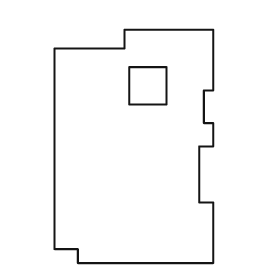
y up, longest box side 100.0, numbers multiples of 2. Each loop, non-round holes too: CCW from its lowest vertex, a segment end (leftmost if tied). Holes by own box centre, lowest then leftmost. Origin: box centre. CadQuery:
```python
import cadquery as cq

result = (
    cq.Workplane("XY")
    .moveTo(-24.0, -50.0)
    .lineTo(34.0, -50.0)
    .lineTo(34.0, -24.0)
    .lineTo(28.0, -24.0)
    .lineTo(28.0, 0.0)
    .lineTo(34.0, 0.0)
    .lineTo(34.0, 10.0)
    .lineTo(30.0, 10.0)
    .lineTo(30.0, 24.0)
    .lineTo(34.0, 24.0)
    .lineTo(34.0, 50.0)
    .lineTo(-4.0, 50.0)
    .lineTo(-4.0, 42.0)
    .lineTo(-34.0, 42.0)
    .lineTo(-34.0, -44.0)
    .lineTo(-24.0, -44.0)
    .close()
    .moveTo(-2.0, 18.0)
    .lineTo(14.0, 18.0)
    .lineTo(14.0, 34.0)
    .lineTo(-2.0, 34.0)
    .close()
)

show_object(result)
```